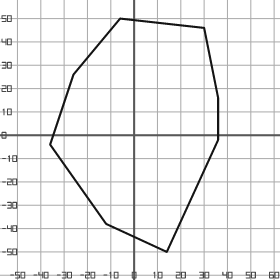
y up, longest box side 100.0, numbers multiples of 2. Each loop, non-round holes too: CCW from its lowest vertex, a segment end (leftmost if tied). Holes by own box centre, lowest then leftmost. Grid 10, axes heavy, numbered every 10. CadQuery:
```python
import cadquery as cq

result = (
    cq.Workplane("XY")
    .moveTo(14.0, -50.0)
    .lineTo(36.0, -2.0)
    .lineTo(36.0, 16.0)
    .lineTo(30.0, 46.0)
    .lineTo(-6.0, 50.0)
    .lineTo(-26.0, 26.0)
    .lineTo(-36.0, -4.0)
    .lineTo(-12.0, -38.0)
    .close()
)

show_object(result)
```